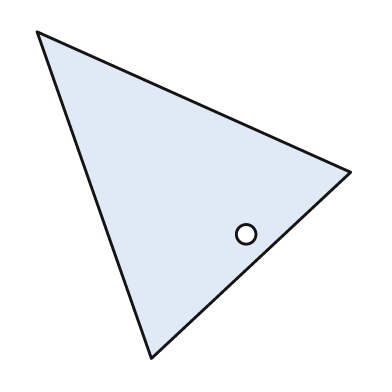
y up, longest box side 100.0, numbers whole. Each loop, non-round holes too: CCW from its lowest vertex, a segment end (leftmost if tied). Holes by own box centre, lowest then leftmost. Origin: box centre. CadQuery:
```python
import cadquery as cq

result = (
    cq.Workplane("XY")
    .moveTo(-13.0, -50.0)
    .lineTo(48.0, 7.0)
    .lineTo(-48.0, 50.0)
    .close()
    .moveTo(16.0, -12.0)
    .circle(3.0)
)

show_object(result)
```